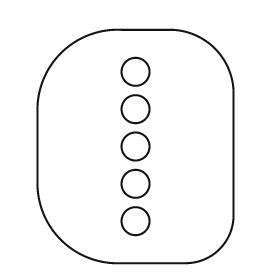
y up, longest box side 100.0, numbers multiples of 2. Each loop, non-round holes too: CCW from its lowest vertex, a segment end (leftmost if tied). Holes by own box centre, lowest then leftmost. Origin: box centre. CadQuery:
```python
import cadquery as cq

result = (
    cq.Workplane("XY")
    .moveTo(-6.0, -50.0)
    .lineTo(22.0, -50.0)
    .threePointArc((36.0, -44.0), (42.0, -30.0))
    .lineTo(42.0, 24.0)
    .threePointArc((34.0, 42.0), (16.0, 50.0))
    .lineTo(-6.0, 50.0)
    .threePointArc((-32.0, 40.0), (-42.0, 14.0))
    .lineTo(-42.0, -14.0)
    .threePointArc((-32.0, -40.0), (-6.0, -50.0))
    .close()
    .moveTo(0.0, -32.0)
    .circle(6.0)
    .moveTo(0.0, -16.0)
    .circle(6.0)
    .moveTo(0.0, 0.0)
    .circle(6.0)
    .moveTo(0.0, 16.0)
    .circle(6.0)
    .moveTo(0.0, 32.0)
    .circle(6.0)
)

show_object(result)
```